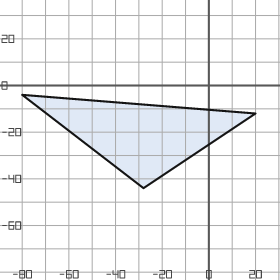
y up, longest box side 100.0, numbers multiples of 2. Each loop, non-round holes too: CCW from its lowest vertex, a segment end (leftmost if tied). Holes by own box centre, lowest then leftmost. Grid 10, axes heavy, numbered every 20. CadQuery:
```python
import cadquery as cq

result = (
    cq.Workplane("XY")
    .moveTo(-28.0, -44.0)
    .lineTo(20.0, -12.0)
    .lineTo(-80.0, -4.0)
    .close()
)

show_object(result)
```